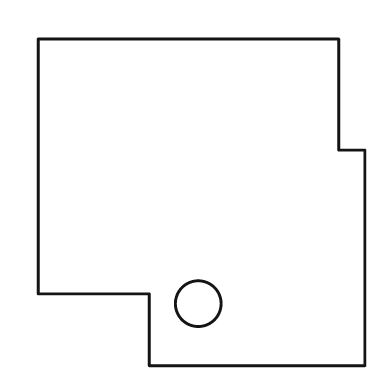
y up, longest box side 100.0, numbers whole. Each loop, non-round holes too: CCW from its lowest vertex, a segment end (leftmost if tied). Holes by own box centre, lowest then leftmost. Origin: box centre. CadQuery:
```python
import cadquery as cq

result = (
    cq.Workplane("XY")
    .moveTo(-16.0, -50.0)
    .lineTo(50.0, -50.0)
    .lineTo(50.0, 16.0)
    .lineTo(42.0, 16.0)
    .lineTo(42.0, 50.0)
    .lineTo(-50.0, 50.0)
    .lineTo(-50.0, -28.0)
    .lineTo(-16.0, -28.0)
    .close()
    .moveTo(-1.0, -31.0)
    .circle(7.0)
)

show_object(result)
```